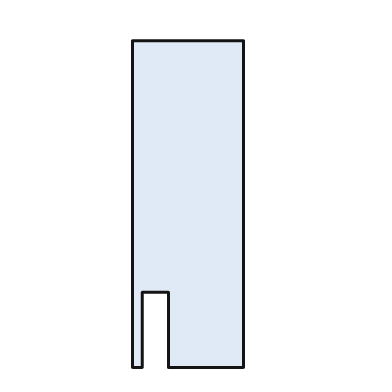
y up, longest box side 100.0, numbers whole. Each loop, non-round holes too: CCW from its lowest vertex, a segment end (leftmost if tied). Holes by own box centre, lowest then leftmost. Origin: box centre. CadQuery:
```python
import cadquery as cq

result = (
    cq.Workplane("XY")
    .moveTo(-17.0, -50.0)
    .lineTo(-14.0, -50.0)
    .lineTo(-14.0, -27.0)
    .lineTo(-6.0, -27.0)
    .lineTo(-6.0, -50.0)
    .lineTo(17.0, -50.0)
    .lineTo(17.0, 50.0)
    .lineTo(-17.0, 50.0)
    .close()
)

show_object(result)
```